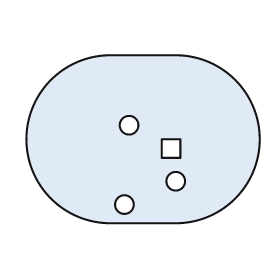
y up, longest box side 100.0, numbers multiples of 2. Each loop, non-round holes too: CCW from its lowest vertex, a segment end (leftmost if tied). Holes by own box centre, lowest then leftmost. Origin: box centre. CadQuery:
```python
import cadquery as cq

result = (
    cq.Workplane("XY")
    .moveTo(-14.0, -36.0)
    .lineTo(14.0, -36.0)
    .threePointArc((50.0, 0.0), (14.0, 36.0))
    .lineTo(-14.0, 36.0)
    .threePointArc((-50.0, 0.0), (-14.0, -36.0))
    .close()
    .moveTo(-8.0, -28.0)
    .circle(4.0)
    .moveTo(14.0, -18.0)
    .circle(4.0)
    .moveTo(8.0, -8.0)
    .lineTo(16.0, -8.0)
    .lineTo(16.0, 0.0)
    .lineTo(8.0, 0.0)
    .close()
    .moveTo(-6.0, 6.0)
    .circle(4.0)
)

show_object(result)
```